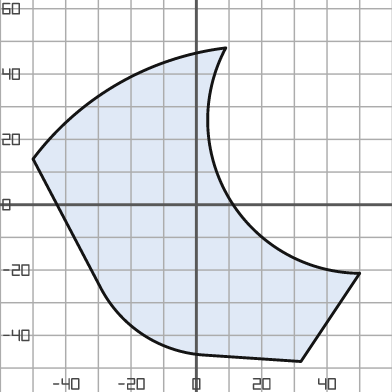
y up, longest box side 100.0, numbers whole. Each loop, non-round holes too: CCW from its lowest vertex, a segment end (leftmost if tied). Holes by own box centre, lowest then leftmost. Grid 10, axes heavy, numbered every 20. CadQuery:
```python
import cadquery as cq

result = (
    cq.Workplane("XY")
    .moveTo(32.0, -48.0)
    .lineTo(50.0, -21.0)
    .threePointArc((10.0, 2.0), (9.0, 48.0))
    .threePointArc((-24.0, 37.0), (-50.0, 14.0))
    .lineTo(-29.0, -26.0)
    .threePointArc((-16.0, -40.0), (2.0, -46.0))
    .close()
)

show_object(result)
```